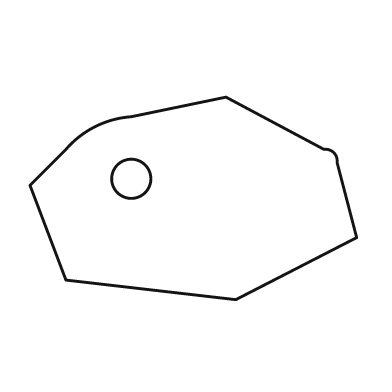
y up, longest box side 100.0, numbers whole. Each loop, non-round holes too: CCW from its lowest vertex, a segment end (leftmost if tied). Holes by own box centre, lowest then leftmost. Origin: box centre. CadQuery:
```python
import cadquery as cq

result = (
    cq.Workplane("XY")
    .moveTo(13.0, -31.0)
    .lineTo(50.0, -12.0)
    .lineTo(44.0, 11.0)
    .threePointArc((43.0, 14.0), (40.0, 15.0))
    .lineTo(10.0, 31.0)
    .lineTo(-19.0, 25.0)
    .threePointArc((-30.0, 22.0), (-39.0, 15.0))
    .lineTo(-50.0, 4.0)
    .lineTo(-39.0, -25.0)
    .close()
    .moveTo(-19.0, 6.0)
    .circle(6.0)
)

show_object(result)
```